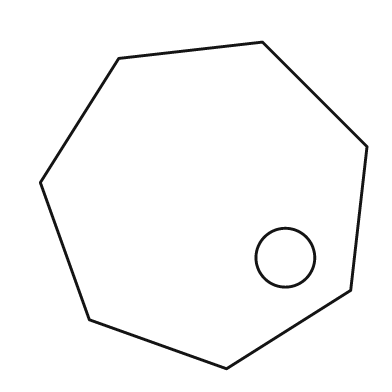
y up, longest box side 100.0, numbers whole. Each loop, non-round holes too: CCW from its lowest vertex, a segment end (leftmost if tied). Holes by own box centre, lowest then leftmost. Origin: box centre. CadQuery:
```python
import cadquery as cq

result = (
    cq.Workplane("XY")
    .moveTo(7.0, -50.0)
    .lineTo(45.0, -26.0)
    .lineTo(50.0, 18.0)
    .lineTo(18.0, 50.0)
    .lineTo(-26.0, 45.0)
    .lineTo(-50.0, 7.0)
    .lineTo(-35.0, -35.0)
    .close()
    .moveTo(25.0, -16.0)
    .circle(9.0)
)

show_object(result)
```